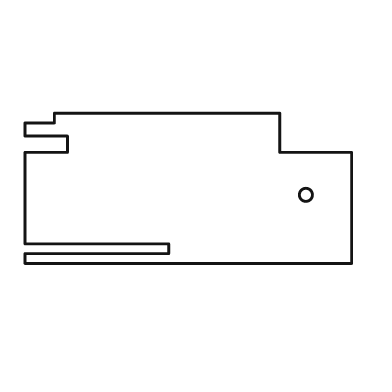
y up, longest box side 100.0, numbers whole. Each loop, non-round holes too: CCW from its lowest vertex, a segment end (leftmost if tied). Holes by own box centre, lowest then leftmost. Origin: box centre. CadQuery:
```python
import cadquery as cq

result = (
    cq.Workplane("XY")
    .moveTo(-50.0, -23.0)
    .lineTo(50.0, -23.0)
    .lineTo(50.0, 11.0)
    .lineTo(28.0, 11.0)
    .lineTo(28.0, 23.0)
    .lineTo(-41.0, 23.0)
    .lineTo(-41.0, 20.0)
    .lineTo(-50.0, 20.0)
    .lineTo(-50.0, 16.0)
    .lineTo(-37.0, 16.0)
    .lineTo(-37.0, 11.0)
    .lineTo(-50.0, 11.0)
    .lineTo(-50.0, -17.0)
    .lineTo(-6.0, -17.0)
    .lineTo(-6.0, -20.0)
    .lineTo(-50.0, -20.0)
    .close()
    .moveTo(36.0, -2.0)
    .circle(2.0)
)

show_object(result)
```